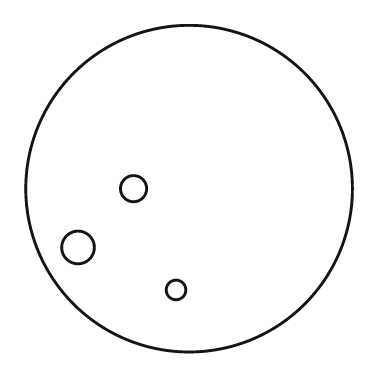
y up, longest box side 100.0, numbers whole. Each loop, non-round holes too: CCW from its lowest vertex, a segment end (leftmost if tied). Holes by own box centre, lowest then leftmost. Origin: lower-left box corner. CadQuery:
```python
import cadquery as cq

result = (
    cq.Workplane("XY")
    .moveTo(50.0, 50.0)
    .circle(50.0)
    .moveTo(46.0, 19.0)
    .circle(3.0)
    .moveTo(16.0, 32.0)
    .circle(5.0)
    .moveTo(33.0, 50.0)
    .circle(4.0)
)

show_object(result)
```